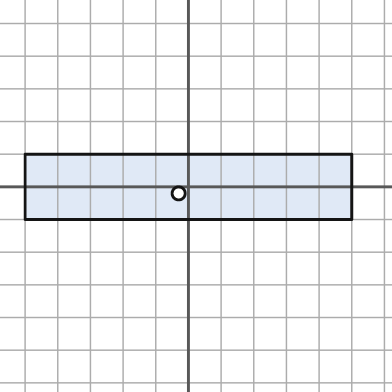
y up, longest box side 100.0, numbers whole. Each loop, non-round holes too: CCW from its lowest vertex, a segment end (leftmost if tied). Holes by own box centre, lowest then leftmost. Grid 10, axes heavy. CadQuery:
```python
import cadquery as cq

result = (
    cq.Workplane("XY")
    .moveTo(-50.0, -10.0)
    .lineTo(50.0, -10.0)
    .lineTo(50.0, 10.0)
    .lineTo(-50.0, 10.0)
    .close()
    .moveTo(-3.0, -2.0)
    .circle(2.0)
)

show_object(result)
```